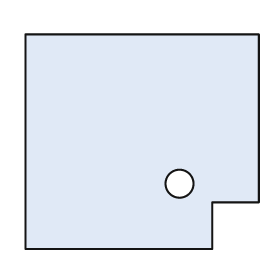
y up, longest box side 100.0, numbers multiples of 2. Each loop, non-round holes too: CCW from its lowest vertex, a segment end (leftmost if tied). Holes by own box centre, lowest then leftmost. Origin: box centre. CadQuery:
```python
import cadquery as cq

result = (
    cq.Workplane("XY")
    .moveTo(-50.0, -46.0)
    .lineTo(30.0, -46.0)
    .lineTo(30.0, -26.0)
    .lineTo(50.0, -26.0)
    .lineTo(50.0, 46.0)
    .lineTo(-50.0, 46.0)
    .close()
    .moveTo(16.0, -18.0)
    .circle(6.0)
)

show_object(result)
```